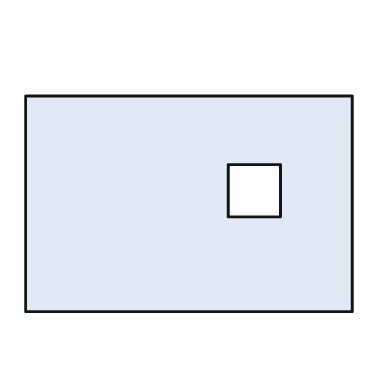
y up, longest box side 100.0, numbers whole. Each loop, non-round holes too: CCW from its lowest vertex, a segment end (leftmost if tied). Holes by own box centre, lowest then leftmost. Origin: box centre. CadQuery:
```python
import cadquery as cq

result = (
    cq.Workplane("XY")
    .moveTo(-50.0, -33.0)
    .lineTo(50.0, -33.0)
    .lineTo(50.0, 33.0)
    .lineTo(-50.0, 33.0)
    .close()
    .moveTo(12.0, -4.0)
    .lineTo(28.0, -4.0)
    .lineTo(28.0, 12.0)
    .lineTo(12.0, 12.0)
    .close()
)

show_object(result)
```